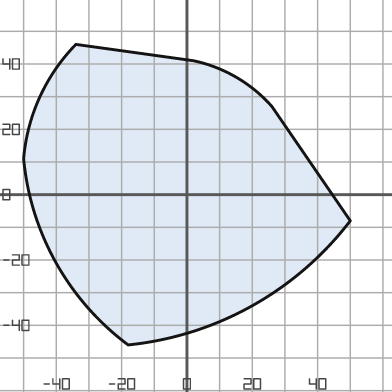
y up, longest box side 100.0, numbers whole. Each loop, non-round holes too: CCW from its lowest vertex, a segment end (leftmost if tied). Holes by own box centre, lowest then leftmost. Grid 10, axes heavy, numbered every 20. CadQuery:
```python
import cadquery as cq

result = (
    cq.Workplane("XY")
    .moveTo(-18.0, -46.0)
    .threePointArc((20.0, -34.0), (50.0, -8.0))
    .lineTo(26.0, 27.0)
    .threePointArc((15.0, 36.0), (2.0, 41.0))
    .lineTo(-34.0, 46.0)
    .threePointArc((-45.0, 30.0), (-50.0, 11.0))
    .threePointArc((-40.0, -21.0), (-18.0, -46.0))
    .close()
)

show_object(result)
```